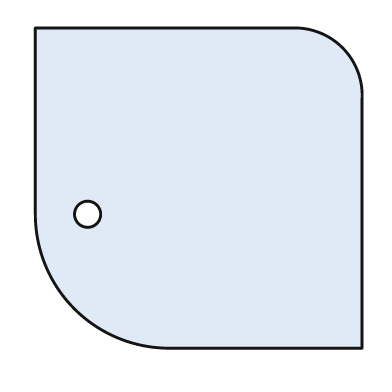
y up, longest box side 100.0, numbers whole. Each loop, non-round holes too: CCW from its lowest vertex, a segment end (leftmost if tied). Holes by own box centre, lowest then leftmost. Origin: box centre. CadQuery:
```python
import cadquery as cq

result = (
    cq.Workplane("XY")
    .moveTo(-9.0, -49.0)
    .lineTo(50.0, -49.0)
    .lineTo(50.0, 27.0)
    .threePointArc((44.0, 43.0), (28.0, 49.0))
    .lineTo(-50.0, 49.0)
    .lineTo(-50.0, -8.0)
    .threePointArc((-38.0, -37.0), (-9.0, -49.0))
    .close()
    .moveTo(-34.0, -8.0)
    .circle(4.0)
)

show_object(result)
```